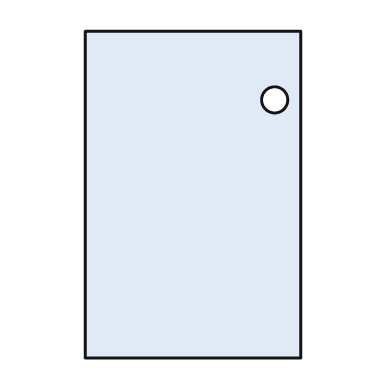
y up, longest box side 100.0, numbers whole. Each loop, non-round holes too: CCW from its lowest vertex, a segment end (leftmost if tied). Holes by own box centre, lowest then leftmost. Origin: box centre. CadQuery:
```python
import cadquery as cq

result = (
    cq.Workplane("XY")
    .moveTo(-33.0, -50.0)
    .lineTo(33.0, -50.0)
    .lineTo(33.0, 50.0)
    .lineTo(-33.0, 50.0)
    .close()
    .moveTo(25.0, 29.0)
    .circle(4.0)
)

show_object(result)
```